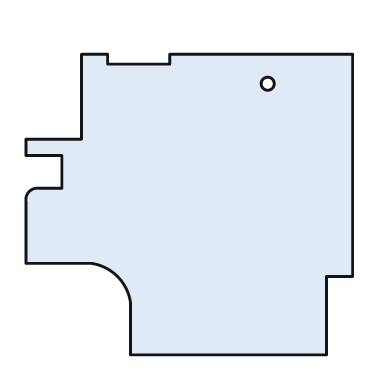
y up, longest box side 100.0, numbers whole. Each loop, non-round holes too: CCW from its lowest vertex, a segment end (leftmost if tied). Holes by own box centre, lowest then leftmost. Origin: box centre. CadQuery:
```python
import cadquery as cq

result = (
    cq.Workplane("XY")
    .moveTo(-18.0, -46.0)
    .lineTo(42.0, -46.0)
    .lineTo(42.0, -22.0)
    .lineTo(50.0, -22.0)
    .lineTo(50.0, 46.0)
    .lineTo(-6.0, 46.0)
    .lineTo(-6.0, 43.0)
    .lineTo(-25.0, 43.0)
    .lineTo(-25.0, 46.0)
    .lineTo(-33.0, 46.0)
    .lineTo(-33.0, 20.0)
    .lineTo(-50.0, 20.0)
    .lineTo(-50.0, 15.0)
    .lineTo(-39.0, 15.0)
    .lineTo(-39.0, 5.0)
    .lineTo(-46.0, 5.0)
    .threePointArc((-49.0, 4.0), (-50.0, 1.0))
    .lineTo(-50.0, -18.0)
    .lineTo(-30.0, -18.0)
    .threePointArc((-22.0, -22.0), (-18.0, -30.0))
    .close()
    .moveTo(24.0, 37.0)
    .circle(2.0)
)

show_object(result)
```